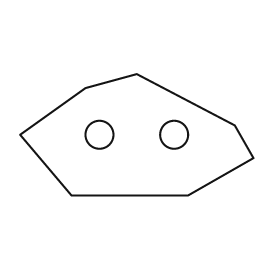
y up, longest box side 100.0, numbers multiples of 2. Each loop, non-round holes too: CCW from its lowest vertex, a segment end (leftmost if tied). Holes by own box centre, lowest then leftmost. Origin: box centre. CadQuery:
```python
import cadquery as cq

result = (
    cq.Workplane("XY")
    .moveTo(-28.0, -26.0)
    .lineTo(22.0, -26.0)
    .lineTo(50.0, -10.0)
    .lineTo(42.0, 4.0)
    .lineTo(0.0, 26.0)
    .lineTo(-22.0, 20.0)
    .lineTo(-50.0, 0.0)
    .close()
    .moveTo(-16.0, 0.0)
    .circle(6.0)
    .moveTo(16.0, 0.0)
    .circle(6.0)
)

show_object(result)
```